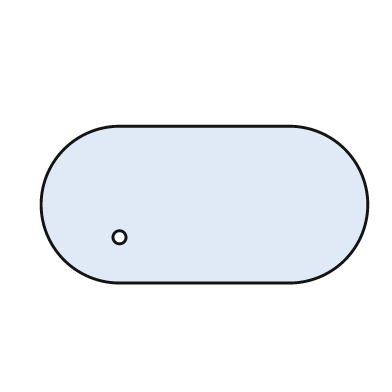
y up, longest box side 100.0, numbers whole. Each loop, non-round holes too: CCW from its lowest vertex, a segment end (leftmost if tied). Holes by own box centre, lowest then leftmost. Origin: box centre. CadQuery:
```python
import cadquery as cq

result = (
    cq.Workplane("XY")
    .moveTo(-26.0, -24.0)
    .lineTo(26.0, -24.0)
    .threePointArc((50.0, 0.0), (26.0, 24.0))
    .lineTo(-26.0, 24.0)
    .threePointArc((-50.0, 0.0), (-26.0, -24.0))
    .close()
    .moveTo(-26.0, -10.0)
    .circle(2.0)
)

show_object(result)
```